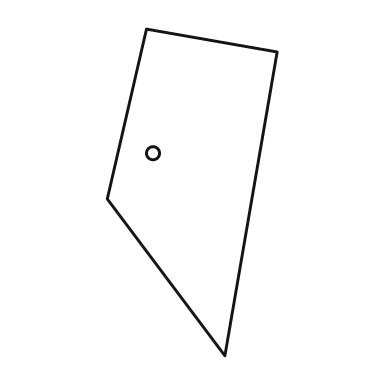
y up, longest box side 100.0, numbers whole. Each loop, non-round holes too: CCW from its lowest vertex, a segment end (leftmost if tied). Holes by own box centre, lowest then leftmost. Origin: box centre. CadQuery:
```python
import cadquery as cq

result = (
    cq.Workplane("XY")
    .moveTo(10.0, -50.0)
    .lineTo(26.0, 43.0)
    .lineTo(-14.0, 50.0)
    .lineTo(-26.0, -2.0)
    .close()
    .moveTo(-12.0, 12.0)
    .circle(2.0)
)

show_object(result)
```